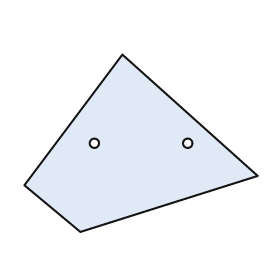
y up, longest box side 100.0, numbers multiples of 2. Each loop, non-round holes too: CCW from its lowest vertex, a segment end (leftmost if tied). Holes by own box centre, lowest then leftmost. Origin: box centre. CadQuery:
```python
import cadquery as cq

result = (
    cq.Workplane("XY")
    .moveTo(-26.0, -38.0)
    .lineTo(50.0, -14.0)
    .lineTo(-8.0, 38.0)
    .lineTo(-50.0, -18.0)
    .close()
    .moveTo(-20.0, 0.0)
    .circle(2.0)
    .moveTo(20.0, 0.0)
    .circle(2.0)
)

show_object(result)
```